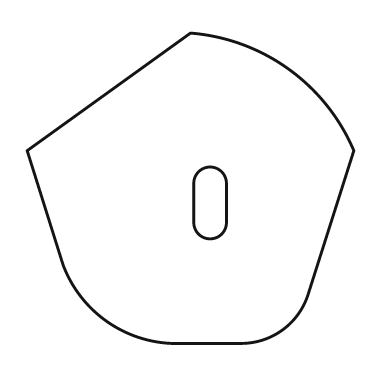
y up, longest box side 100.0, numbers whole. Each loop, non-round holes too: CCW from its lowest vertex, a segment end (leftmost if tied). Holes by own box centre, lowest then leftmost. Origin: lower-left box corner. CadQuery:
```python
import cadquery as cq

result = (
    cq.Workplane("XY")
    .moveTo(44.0, 0.0)
    .lineTo(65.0, 0.0)
    .threePointArc((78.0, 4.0), (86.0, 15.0))
    .lineTo(100.0, 59.0)
    .threePointArc((80.0, 84.0), (50.0, 95.0))
    .lineTo(0.0, 59.0)
    .lineTo(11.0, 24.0)
    .threePointArc((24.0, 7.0), (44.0, 0.0))
    .close()
    .moveTo(51.0, 37.0)
    .threePointArc((56.0, 32.0), (61.0, 37.0))
    .lineTo(61.0, 49.0)
    .threePointArc((56.0, 54.0), (51.0, 49.0))
    .close()
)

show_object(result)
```